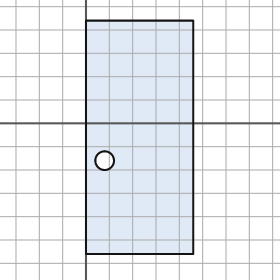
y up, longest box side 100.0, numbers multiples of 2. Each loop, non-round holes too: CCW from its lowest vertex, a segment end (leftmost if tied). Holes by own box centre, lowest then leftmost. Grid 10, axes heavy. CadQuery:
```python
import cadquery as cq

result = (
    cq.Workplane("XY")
    .moveTo(0.0, -56.0)
    .lineTo(46.0, -56.0)
    .lineTo(46.0, 44.0)
    .lineTo(0.0, 44.0)
    .close()
    .moveTo(8.0, -16.0)
    .circle(4.0)
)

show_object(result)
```